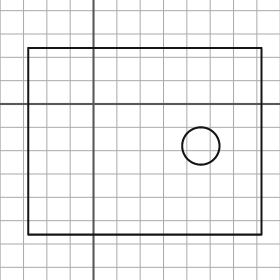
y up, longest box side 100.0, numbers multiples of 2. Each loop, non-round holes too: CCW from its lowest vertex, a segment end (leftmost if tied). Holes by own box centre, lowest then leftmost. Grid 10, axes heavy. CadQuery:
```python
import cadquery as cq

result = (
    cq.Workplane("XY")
    .moveTo(-28.0, -56.0)
    .lineTo(72.0, -56.0)
    .lineTo(72.0, 24.0)
    .lineTo(-28.0, 24.0)
    .close()
    .moveTo(46.0, -18.0)
    .circle(8.0)
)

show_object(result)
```